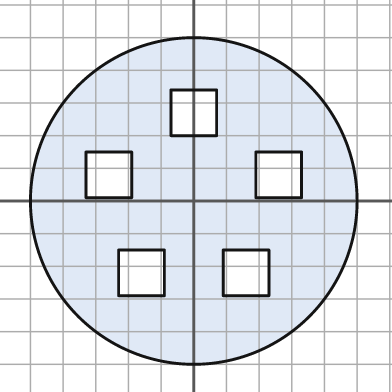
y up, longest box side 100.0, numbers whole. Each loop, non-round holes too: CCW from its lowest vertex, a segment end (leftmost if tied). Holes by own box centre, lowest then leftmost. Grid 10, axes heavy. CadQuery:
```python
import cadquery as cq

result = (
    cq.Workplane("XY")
    .moveTo(0.0, 0.0)
    .circle(50.0)
    .moveTo(-23.0, -29.0)
    .lineTo(-9.0, -29.0)
    .lineTo(-9.0, -15.0)
    .lineTo(-23.0, -15.0)
    .close()
    .moveTo(9.0, -29.0)
    .lineTo(23.0, -29.0)
    .lineTo(23.0, -15.0)
    .lineTo(9.0, -15.0)
    .close()
    .moveTo(-33.0, 1.0)
    .lineTo(-19.0, 1.0)
    .lineTo(-19.0, 15.0)
    .lineTo(-33.0, 15.0)
    .close()
    .moveTo(19.0, 1.0)
    .lineTo(33.0, 1.0)
    .lineTo(33.0, 15.0)
    .lineTo(19.0, 15.0)
    .close()
    .moveTo(-7.0, 20.0)
    .lineTo(7.0, 20.0)
    .lineTo(7.0, 34.0)
    .lineTo(-7.0, 34.0)
    .close()
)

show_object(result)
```